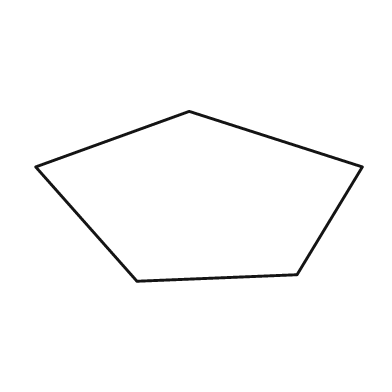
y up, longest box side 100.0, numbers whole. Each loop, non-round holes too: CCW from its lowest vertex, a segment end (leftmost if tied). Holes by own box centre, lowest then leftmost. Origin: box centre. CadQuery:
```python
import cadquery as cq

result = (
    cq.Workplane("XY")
    .moveTo(-19.0, -26.0)
    .lineTo(30.0, -24.0)
    .lineTo(50.0, 9.0)
    .lineTo(-3.0, 26.0)
    .lineTo(-50.0, 9.0)
    .close()
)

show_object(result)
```